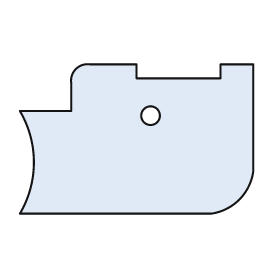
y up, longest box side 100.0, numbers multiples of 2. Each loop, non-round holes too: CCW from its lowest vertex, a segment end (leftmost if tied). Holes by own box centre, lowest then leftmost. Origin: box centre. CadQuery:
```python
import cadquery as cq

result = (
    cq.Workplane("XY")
    .moveTo(-50.0, -32.0)
    .lineTo(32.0, -32.0)
    .threePointArc((44.0, -26.0), (50.0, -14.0))
    .lineTo(50.0, 32.0)
    .lineTo(36.0, 32.0)
    .lineTo(36.0, 26.0)
    .lineTo(0.0, 26.0)
    .lineTo(0.0, 32.0)
    .lineTo(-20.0, 32.0)
    .threePointArc((-26.0, 30.0), (-28.0, 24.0))
    .lineTo(-28.0, 12.0)
    .lineTo(-50.0, 12.0)
    .threePointArc((-44.0, -10.0), (-50.0, -32.0))
    .close()
    .moveTo(6.0, 10.0)
    .circle(4.0)
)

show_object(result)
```